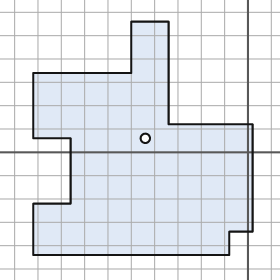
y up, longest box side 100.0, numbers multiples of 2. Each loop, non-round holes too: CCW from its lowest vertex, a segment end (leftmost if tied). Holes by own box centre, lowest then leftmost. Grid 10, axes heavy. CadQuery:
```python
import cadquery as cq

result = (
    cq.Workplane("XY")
    .moveTo(-92.0, -44.0)
    .lineTo(-8.0, -44.0)
    .lineTo(-8.0, -34.0)
    .lineTo(2.0, -34.0)
    .lineTo(2.0, 12.0)
    .lineTo(-34.0, 12.0)
    .lineTo(-34.0, 56.0)
    .lineTo(-50.0, 56.0)
    .lineTo(-50.0, 34.0)
    .lineTo(-92.0, 34.0)
    .lineTo(-92.0, 6.0)
    .lineTo(-76.0, 6.0)
    .lineTo(-76.0, -22.0)
    .lineTo(-92.0, -22.0)
    .close()
    .moveTo(-44.0, 6.0)
    .circle(2.0)
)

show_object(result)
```